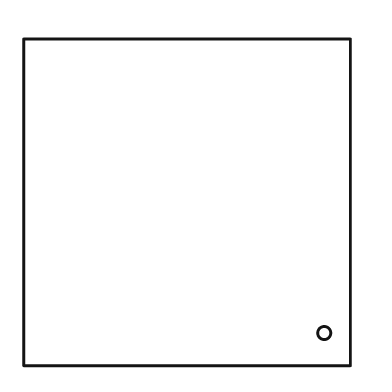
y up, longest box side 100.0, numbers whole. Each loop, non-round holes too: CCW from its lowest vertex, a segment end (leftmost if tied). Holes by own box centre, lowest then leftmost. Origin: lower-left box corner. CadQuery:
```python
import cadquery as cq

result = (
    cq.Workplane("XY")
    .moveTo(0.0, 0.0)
    .lineTo(100.0, 0.0)
    .lineTo(100.0, 100.0)
    .lineTo(0.0, 100.0)
    .close()
    .moveTo(92.0, 10.0)
    .circle(2.0)
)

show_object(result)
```